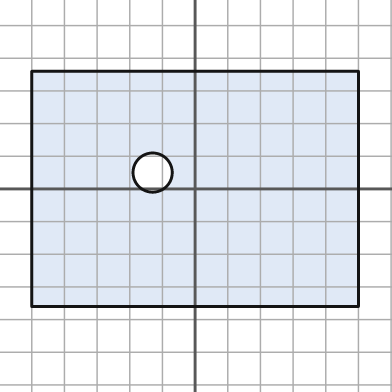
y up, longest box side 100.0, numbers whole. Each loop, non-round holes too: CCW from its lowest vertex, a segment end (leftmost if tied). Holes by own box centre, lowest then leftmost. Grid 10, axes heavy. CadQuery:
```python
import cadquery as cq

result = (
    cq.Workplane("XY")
    .moveTo(-50.0, -36.0)
    .lineTo(50.0, -36.0)
    .lineTo(50.0, 36.0)
    .lineTo(-50.0, 36.0)
    .close()
    .moveTo(-13.0, 5.0)
    .circle(6.0)
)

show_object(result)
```